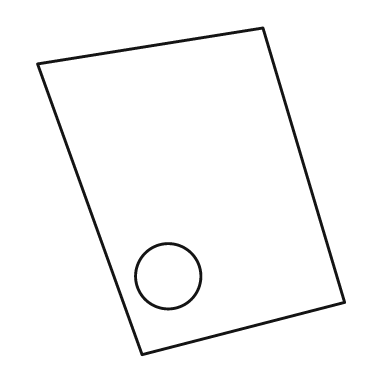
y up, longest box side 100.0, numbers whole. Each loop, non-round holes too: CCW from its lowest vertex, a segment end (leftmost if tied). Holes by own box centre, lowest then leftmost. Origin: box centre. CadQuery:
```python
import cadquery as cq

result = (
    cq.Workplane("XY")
    .moveTo(-15.0, -50.0)
    .lineTo(47.0, -34.0)
    .lineTo(22.0, 50.0)
    .lineTo(-47.0, 39.0)
    .close()
    .moveTo(-7.0, -26.0)
    .circle(10.0)
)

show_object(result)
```